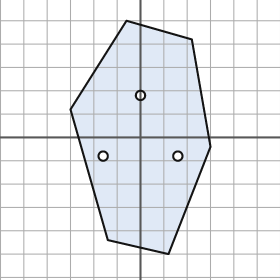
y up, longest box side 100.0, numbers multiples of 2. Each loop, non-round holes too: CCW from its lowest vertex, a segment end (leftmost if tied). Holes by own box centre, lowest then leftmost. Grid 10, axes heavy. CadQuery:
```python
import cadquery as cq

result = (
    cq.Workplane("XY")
    .moveTo(12.0, -50.0)
    .lineTo(30.0, -4.0)
    .lineTo(22.0, 42.0)
    .lineTo(-6.0, 50.0)
    .lineTo(-30.0, 12.0)
    .lineTo(-14.0, -44.0)
    .close()
    .moveTo(-16.0, -8.0)
    .circle(2.0)
    .moveTo(16.0, -8.0)
    .circle(2.0)
    .moveTo(0.0, 18.0)
    .circle(2.0)
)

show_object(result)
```